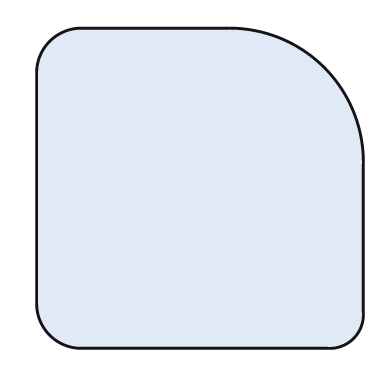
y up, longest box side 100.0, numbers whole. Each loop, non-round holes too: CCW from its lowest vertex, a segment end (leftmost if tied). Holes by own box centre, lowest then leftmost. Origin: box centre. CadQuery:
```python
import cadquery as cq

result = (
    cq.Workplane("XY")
    .moveTo(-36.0, -49.0)
    .lineTo(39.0, -49.0)
    .threePointArc((47.0, -46.0), (50.0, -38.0))
    .lineTo(50.0, 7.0)
    .threePointArc((38.0, 37.0), (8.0, 49.0))
    .lineTo(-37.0, 49.0)
    .threePointArc((-46.0, 45.0), (-50.0, 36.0))
    .lineTo(-50.0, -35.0)
    .threePointArc((-46.0, -45.0), (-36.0, -49.0))
    .close()
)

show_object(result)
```